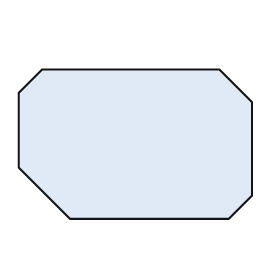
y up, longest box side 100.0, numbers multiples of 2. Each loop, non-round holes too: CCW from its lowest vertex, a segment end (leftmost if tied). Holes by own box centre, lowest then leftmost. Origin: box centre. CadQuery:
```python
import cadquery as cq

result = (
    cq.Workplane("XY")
    .moveTo(-28.0, -32.0)
    .lineTo(40.0, -32.0)
    .lineTo(50.0, -22.0)
    .lineTo(50.0, 18.0)
    .lineTo(36.0, 32.0)
    .lineTo(-40.0, 32.0)
    .lineTo(-50.0, 22.0)
    .lineTo(-50.0, -10.0)
    .close()
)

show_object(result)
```